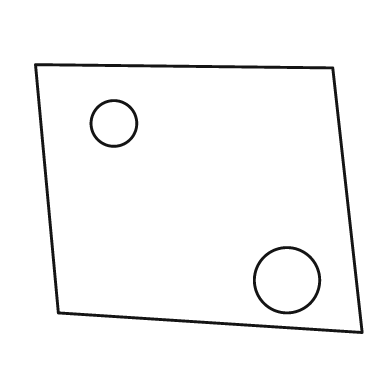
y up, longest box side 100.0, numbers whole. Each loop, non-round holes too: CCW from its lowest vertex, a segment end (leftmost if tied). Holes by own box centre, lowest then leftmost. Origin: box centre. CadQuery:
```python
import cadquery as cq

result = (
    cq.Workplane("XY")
    .moveTo(50.0, -41.0)
    .lineTo(41.0, 40.0)
    .lineTo(-50.0, 41.0)
    .lineTo(-43.0, -35.0)
    .close()
    .moveTo(27.0, -25.0)
    .circle(10.0)
    .moveTo(-26.0, 23.0)
    .circle(7.0)
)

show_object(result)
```